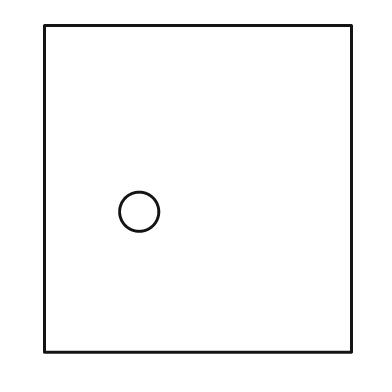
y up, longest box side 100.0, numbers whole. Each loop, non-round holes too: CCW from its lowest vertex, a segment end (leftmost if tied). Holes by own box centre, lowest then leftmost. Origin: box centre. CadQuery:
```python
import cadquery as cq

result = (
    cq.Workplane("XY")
    .moveTo(-47.0, -50.0)
    .lineTo(47.0, -50.0)
    .lineTo(47.0, 50.0)
    .lineTo(-47.0, 50.0)
    .close()
    .moveTo(-18.0, -7.0)
    .circle(6.0)
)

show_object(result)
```